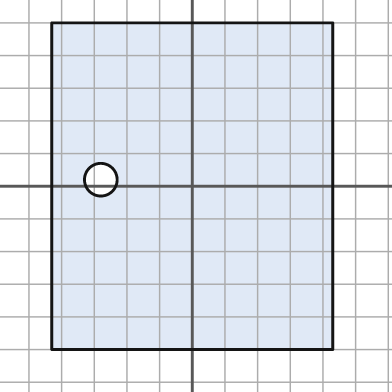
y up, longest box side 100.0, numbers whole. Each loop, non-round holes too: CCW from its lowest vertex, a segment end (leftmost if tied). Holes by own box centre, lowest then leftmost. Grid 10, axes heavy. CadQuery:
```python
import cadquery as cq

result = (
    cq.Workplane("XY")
    .moveTo(-43.0, -50.0)
    .lineTo(43.0, -50.0)
    .lineTo(43.0, 50.0)
    .lineTo(-43.0, 50.0)
    .close()
    .moveTo(-28.0, 2.0)
    .circle(5.0)
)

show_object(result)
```